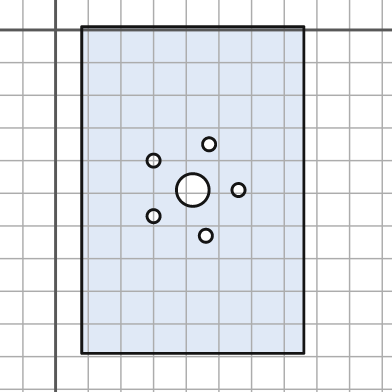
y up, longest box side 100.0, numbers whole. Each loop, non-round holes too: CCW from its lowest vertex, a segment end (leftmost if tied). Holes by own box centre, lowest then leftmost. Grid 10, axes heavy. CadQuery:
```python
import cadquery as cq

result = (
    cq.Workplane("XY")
    .moveTo(8.0, -99.0)
    .lineTo(76.0, -99.0)
    .lineTo(76.0, 1.0)
    .lineTo(8.0, 1.0)
    .close()
    .moveTo(46.0, -63.0)
    .circle(2.0)
    .moveTo(30.0, -57.0)
    .circle(2.0)
    .moveTo(42.0, -49.0)
    .circle(5.0)
    .moveTo(56.0, -49.0)
    .circle(2.0)
    .moveTo(30.0, -40.0)
    .circle(2.0)
    .moveTo(47.0, -35.0)
    .circle(2.0)
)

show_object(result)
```